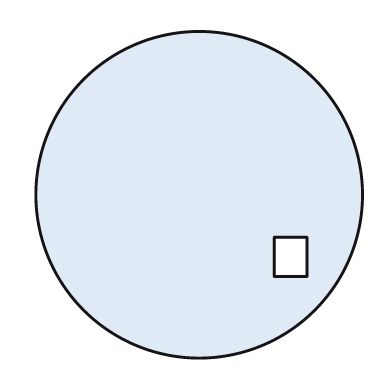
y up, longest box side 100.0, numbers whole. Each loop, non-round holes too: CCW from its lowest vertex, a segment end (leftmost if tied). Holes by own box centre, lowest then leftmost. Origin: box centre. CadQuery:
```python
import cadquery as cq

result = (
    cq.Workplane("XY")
    .moveTo(0.0, 0.0)
    .circle(50.0)
    .moveTo(23.0, -25.0)
    .lineTo(33.0, -25.0)
    .lineTo(33.0, -13.0)
    .lineTo(23.0, -13.0)
    .close()
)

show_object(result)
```